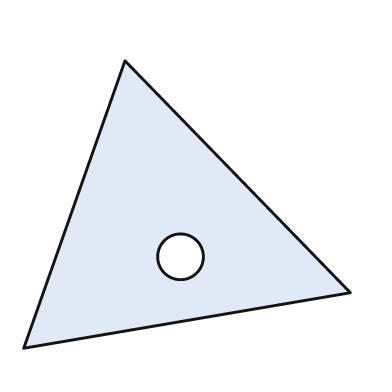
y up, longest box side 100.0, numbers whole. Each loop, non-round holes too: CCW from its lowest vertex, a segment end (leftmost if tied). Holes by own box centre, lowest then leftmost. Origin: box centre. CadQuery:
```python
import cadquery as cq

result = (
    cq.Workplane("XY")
    .moveTo(-50.0, -44.0)
    .lineTo(50.0, -27.0)
    .lineTo(-19.0, 44.0)
    .close()
    .moveTo(-2.0, -16.0)
    .circle(7.0)
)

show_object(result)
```